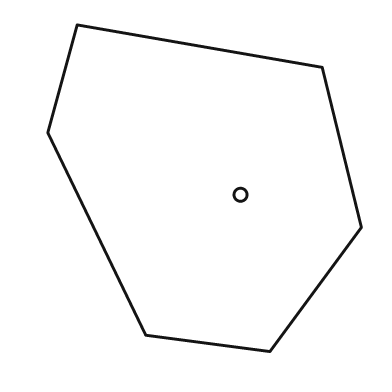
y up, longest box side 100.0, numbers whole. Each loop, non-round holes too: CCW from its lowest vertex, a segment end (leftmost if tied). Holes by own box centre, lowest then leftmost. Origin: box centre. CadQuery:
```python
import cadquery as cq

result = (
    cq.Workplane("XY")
    .moveTo(20.0, -50.0)
    .lineTo(48.0, -12.0)
    .lineTo(36.0, 37.0)
    .lineTo(-39.0, 50.0)
    .lineTo(-48.0, 17.0)
    .lineTo(-18.0, -45.0)
    .close()
    .moveTo(11.0, -2.0)
    .circle(2.0)
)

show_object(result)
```